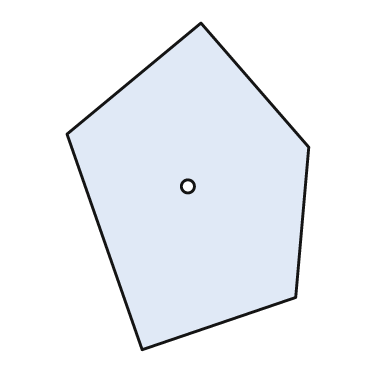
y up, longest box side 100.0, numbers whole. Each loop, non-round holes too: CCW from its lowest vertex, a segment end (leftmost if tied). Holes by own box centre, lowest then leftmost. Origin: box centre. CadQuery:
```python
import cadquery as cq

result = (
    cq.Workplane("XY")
    .moveTo(-14.0, -50.0)
    .lineTo(33.0, -34.0)
    .lineTo(37.0, 12.0)
    .lineTo(4.0, 50.0)
    .lineTo(-37.0, 16.0)
    .close()
    .moveTo(0.0, 0.0)
    .circle(2.0)
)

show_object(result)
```